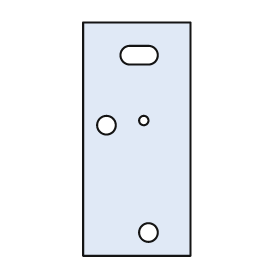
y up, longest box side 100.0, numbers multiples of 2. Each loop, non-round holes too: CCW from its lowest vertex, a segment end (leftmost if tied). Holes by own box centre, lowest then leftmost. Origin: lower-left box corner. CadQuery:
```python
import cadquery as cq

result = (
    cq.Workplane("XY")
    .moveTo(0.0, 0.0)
    .lineTo(46.0, 0.0)
    .lineTo(46.0, 100.0)
    .lineTo(0.0, 100.0)
    .close()
    .moveTo(28.0, 10.0)
    .circle(4.0)
    .moveTo(10.0, 56.0)
    .circle(4.0)
    .moveTo(26.0, 58.0)
    .circle(2.0)
    .moveTo(20.0, 82.0)
    .lineTo(28.0, 82.0)
    .threePointArc((32.0, 86.0), (28.0, 90.0))
    .lineTo(20.0, 90.0)
    .threePointArc((16.0, 86.0), (20.0, 82.0))
    .close()
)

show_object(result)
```